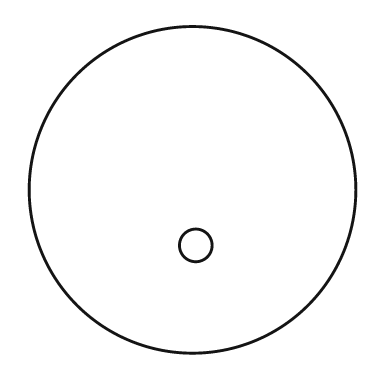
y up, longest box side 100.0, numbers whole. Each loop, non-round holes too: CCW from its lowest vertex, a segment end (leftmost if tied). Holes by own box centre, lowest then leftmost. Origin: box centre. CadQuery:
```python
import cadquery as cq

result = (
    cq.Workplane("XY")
    .moveTo(0.0, 0.0)
    .circle(50.0)
    .moveTo(1.0, -17.0)
    .circle(5.0)
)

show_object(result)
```